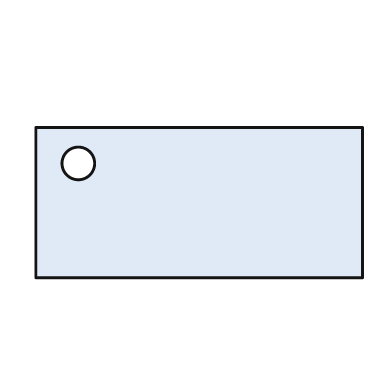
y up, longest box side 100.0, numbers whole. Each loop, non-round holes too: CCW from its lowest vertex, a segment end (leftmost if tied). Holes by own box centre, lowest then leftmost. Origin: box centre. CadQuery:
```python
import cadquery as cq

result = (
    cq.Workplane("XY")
    .moveTo(-50.0, -23.0)
    .lineTo(50.0, -23.0)
    .lineTo(50.0, 23.0)
    .lineTo(-50.0, 23.0)
    .close()
    .moveTo(-37.0, 12.0)
    .circle(5.0)
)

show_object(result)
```